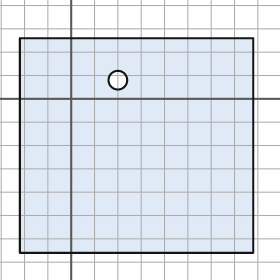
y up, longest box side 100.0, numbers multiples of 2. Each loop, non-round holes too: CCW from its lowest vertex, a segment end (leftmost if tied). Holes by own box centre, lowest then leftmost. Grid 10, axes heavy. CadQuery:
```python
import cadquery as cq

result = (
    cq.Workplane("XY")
    .moveTo(-22.0, -66.0)
    .lineTo(78.0, -66.0)
    .lineTo(78.0, 26.0)
    .lineTo(-22.0, 26.0)
    .close()
    .moveTo(20.0, 8.0)
    .circle(4.0)
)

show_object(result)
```